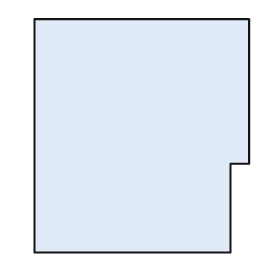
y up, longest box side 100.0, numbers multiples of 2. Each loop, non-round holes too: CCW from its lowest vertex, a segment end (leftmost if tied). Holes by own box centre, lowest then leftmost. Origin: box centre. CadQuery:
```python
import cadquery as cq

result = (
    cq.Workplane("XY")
    .moveTo(-46.0, -50.0)
    .lineTo(38.0, -50.0)
    .lineTo(38.0, -12.0)
    .lineTo(46.0, -12.0)
    .lineTo(46.0, 50.0)
    .lineTo(-46.0, 50.0)
    .close()
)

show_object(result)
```